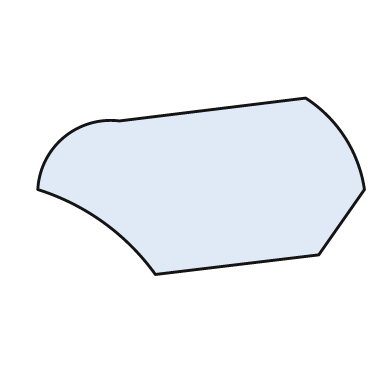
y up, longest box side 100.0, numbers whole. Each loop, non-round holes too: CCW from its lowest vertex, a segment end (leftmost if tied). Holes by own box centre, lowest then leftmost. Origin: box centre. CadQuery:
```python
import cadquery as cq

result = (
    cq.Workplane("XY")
    .moveTo(-14.0, -27.0)
    .lineTo(36.0, -21.0)
    .lineTo(50.0, -1.0)
    .threePointArc((44.0, 15.0), (32.0, 27.0))
    .lineTo(-25.0, 20.0)
    .threePointArc((-42.0, 15.0), (-50.0, -1.0))
    .threePointArc((-30.0, -11.0), (-14.0, -27.0))
    .close()
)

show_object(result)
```